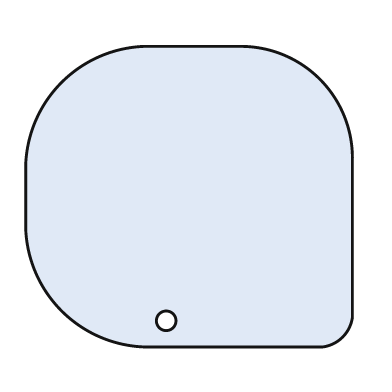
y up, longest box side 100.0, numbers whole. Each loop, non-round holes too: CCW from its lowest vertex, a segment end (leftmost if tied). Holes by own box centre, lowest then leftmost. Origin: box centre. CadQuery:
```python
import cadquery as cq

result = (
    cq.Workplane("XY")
    .moveTo(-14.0, -46.0)
    .lineTo(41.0, -46.0)
    .threePointArc((47.0, -43.0), (50.0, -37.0))
    .lineTo(50.0, 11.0)
    .threePointArc((40.0, 36.0), (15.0, 46.0))
    .lineTo(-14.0, 46.0)
    .threePointArc((-39.0, 35.0), (-50.0, 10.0))
    .lineTo(-50.0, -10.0)
    .threePointArc((-39.0, -35.0), (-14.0, -46.0))
    .close()
    .moveTo(-7.0, -38.0)
    .circle(3.0)
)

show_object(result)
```